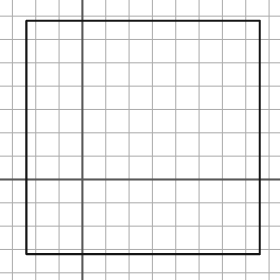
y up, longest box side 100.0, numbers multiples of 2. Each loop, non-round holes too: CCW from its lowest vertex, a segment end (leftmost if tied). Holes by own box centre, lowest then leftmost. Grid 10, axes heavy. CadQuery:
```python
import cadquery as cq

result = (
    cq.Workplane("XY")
    .moveTo(-24.0, -32.0)
    .lineTo(76.0, -32.0)
    .lineTo(76.0, 68.0)
    .lineTo(-24.0, 68.0)
    .close()
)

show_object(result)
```